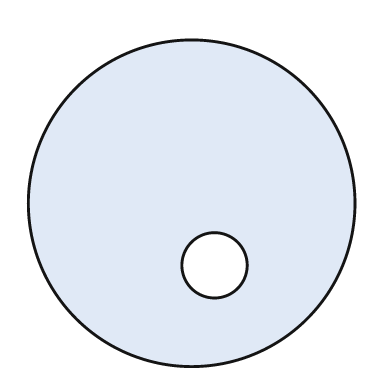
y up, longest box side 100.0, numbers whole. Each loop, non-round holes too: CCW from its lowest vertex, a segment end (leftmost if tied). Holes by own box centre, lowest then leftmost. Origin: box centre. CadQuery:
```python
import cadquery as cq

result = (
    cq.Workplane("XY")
    .moveTo(0.0, 0.0)
    .circle(50.0)
    .moveTo(7.0, -19.0)
    .circle(10.0)
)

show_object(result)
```